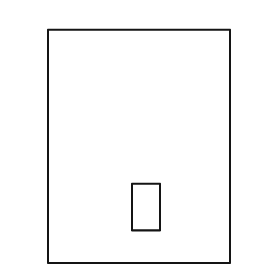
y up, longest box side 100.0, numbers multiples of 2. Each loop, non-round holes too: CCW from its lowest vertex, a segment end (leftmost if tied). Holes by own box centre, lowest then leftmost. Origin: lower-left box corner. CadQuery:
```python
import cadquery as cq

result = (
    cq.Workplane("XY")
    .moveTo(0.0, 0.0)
    .lineTo(78.0, 0.0)
    .lineTo(78.0, 100.0)
    .lineTo(0.0, 100.0)
    .close()
    .moveTo(36.0, 14.0)
    .lineTo(48.0, 14.0)
    .lineTo(48.0, 34.0)
    .lineTo(36.0, 34.0)
    .close()
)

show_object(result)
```